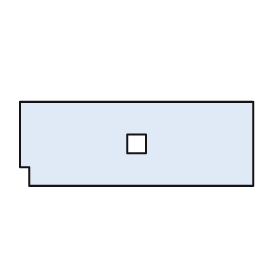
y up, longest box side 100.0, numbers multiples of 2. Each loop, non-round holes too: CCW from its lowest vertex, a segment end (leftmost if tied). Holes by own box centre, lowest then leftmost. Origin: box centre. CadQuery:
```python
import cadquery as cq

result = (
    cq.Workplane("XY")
    .moveTo(-46.0, -18.0)
    .lineTo(50.0, -18.0)
    .lineTo(50.0, 18.0)
    .lineTo(-50.0, 18.0)
    .lineTo(-50.0, -10.0)
    .lineTo(-46.0, -10.0)
    .close()
    .moveTo(-4.0, -4.0)
    .lineTo(4.0, -4.0)
    .lineTo(4.0, 4.0)
    .lineTo(-4.0, 4.0)
    .close()
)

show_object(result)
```